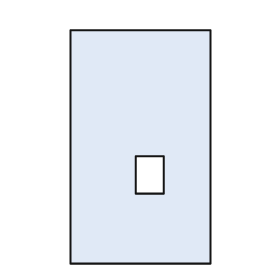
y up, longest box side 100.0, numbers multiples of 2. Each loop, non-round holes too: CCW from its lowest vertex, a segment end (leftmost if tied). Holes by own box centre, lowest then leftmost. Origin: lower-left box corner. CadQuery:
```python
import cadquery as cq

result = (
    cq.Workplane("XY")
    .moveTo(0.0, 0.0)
    .lineTo(60.0, 0.0)
    .lineTo(60.0, 100.0)
    .lineTo(0.0, 100.0)
    .close()
    .moveTo(28.0, 30.0)
    .lineTo(40.0, 30.0)
    .lineTo(40.0, 46.0)
    .lineTo(28.0, 46.0)
    .close()
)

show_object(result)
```